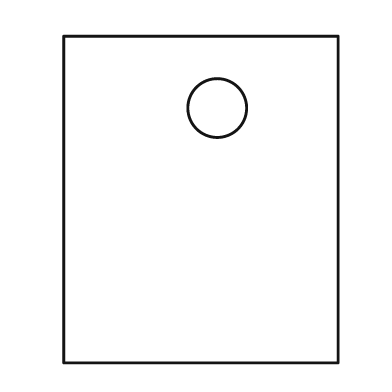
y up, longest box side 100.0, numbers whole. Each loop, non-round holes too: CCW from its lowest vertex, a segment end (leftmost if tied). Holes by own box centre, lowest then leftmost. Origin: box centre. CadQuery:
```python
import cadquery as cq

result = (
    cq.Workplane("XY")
    .moveTo(-42.0, -50.0)
    .lineTo(42.0, -50.0)
    .lineTo(42.0, 50.0)
    .lineTo(-42.0, 50.0)
    .close()
    .moveTo(5.0, 28.0)
    .circle(9.0)
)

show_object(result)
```